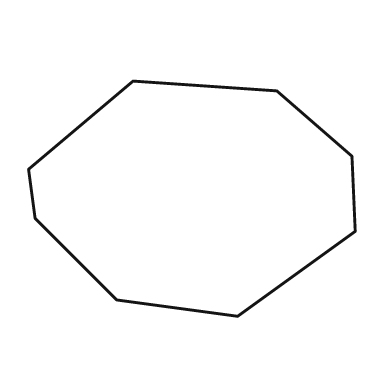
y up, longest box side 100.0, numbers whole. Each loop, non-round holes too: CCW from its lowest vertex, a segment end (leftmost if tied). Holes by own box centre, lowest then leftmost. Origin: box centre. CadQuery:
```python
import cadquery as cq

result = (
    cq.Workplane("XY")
    .moveTo(14.0, -36.0)
    .lineTo(50.0, -10.0)
    .lineTo(49.0, 13.0)
    .lineTo(26.0, 33.0)
    .lineTo(-18.0, 36.0)
    .lineTo(-50.0, 9.0)
    .lineTo(-48.0, -6.0)
    .lineTo(-23.0, -31.0)
    .close()
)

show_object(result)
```